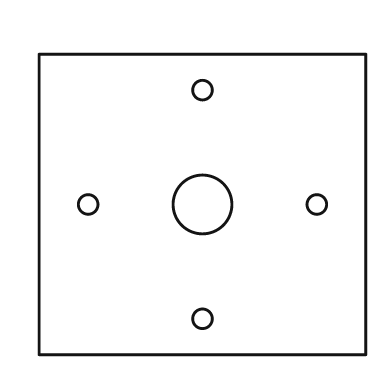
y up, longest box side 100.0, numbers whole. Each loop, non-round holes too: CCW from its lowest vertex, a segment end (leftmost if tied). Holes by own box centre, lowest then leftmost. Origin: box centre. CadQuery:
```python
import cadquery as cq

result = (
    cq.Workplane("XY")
    .moveTo(-50.0, -46.0)
    .lineTo(50.0, -46.0)
    .lineTo(50.0, 46.0)
    .lineTo(-50.0, 46.0)
    .close()
    .moveTo(0.0, -35.0)
    .circle(3.0)
    .moveTo(-35.0, 0.0)
    .circle(3.0)
    .moveTo(0.0, 0.0)
    .circle(9.0)
    .moveTo(35.0, 0.0)
    .circle(3.0)
    .moveTo(0.0, 35.0)
    .circle(3.0)
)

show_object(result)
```